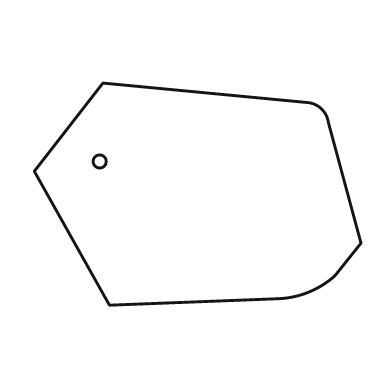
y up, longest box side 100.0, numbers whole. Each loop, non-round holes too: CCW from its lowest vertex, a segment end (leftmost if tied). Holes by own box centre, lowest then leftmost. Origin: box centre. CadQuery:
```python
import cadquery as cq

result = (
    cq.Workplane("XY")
    .moveTo(-27.0, -34.0)
    .lineTo(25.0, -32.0)
    .threePointArc((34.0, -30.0), (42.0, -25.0))
    .lineTo(50.0, -15.0)
    .lineTo(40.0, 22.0)
    .threePointArc((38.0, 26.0), (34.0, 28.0))
    .lineTo(-29.0, 34.0)
    .lineTo(-50.0, 7.0)
    .close()
    .moveTo(-30.0, 10.0)
    .circle(2.0)
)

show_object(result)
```